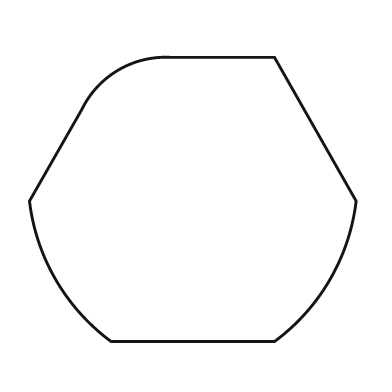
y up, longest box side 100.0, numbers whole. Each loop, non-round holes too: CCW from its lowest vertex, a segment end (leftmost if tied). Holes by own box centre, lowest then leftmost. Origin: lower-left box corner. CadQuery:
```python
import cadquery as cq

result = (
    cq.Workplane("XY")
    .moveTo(25.0, 0.0)
    .lineTo(75.0, 0.0)
    .threePointArc((92.0, 19.0), (100.0, 43.0))
    .lineTo(75.0, 87.0)
    .lineTo(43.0, 87.0)
    .threePointArc((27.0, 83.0), (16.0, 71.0))
    .lineTo(0.0, 43.0)
    .threePointArc((8.0, 19.0), (25.0, 0.0))
    .close()
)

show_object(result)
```